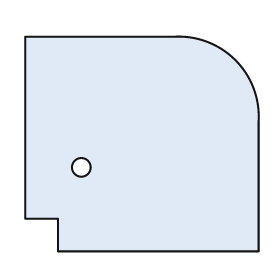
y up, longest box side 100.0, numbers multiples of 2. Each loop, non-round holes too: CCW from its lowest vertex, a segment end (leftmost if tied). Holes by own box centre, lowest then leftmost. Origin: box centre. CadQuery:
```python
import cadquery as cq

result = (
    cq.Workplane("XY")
    .moveTo(-36.0, -46.0)
    .lineTo(50.0, -46.0)
    .lineTo(50.0, 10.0)
    .threePointArc((40.0, 36.0), (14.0, 46.0))
    .lineTo(-50.0, 46.0)
    .lineTo(-50.0, -32.0)
    .lineTo(-36.0, -32.0)
    .close()
    .moveTo(-26.0, -10.0)
    .circle(4.0)
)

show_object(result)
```